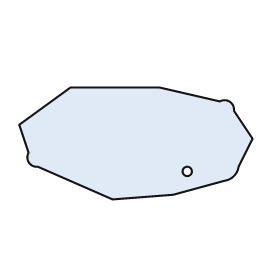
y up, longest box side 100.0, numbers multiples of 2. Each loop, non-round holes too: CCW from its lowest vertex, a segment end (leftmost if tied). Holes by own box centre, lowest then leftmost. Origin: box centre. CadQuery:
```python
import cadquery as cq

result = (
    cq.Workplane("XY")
    .moveTo(-10.0, -24.0)
    .lineTo(16.0, -22.0)
    .lineTo(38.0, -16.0)
    .threePointArc((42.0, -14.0), (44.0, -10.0))
    .lineTo(50.0, 2.0)
    .lineTo(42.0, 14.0)
    .threePointArc((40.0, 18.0), (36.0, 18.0))
    .lineTo(10.0, 24.0)
    .lineTo(-28.0, 24.0)
    .lineTo(-50.0, 8.0)
    .lineTo(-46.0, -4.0)
    .threePointArc((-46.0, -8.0), (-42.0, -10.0))
    .close()
    .moveTo(22.0, -12.0)
    .circle(2.0)
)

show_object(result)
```